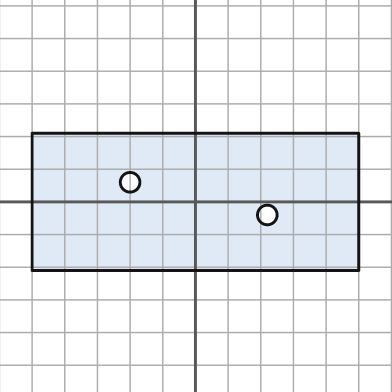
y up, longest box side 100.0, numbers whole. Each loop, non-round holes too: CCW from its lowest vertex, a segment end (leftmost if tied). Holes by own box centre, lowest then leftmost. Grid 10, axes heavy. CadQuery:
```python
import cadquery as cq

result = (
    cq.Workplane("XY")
    .moveTo(-50.0, -21.0)
    .lineTo(50.0, -21.0)
    .lineTo(50.0, 21.0)
    .lineTo(-50.0, 21.0)
    .close()
    .moveTo(22.0, -4.0)
    .circle(3.0)
    .moveTo(-20.0, 6.0)
    .circle(3.0)
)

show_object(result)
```